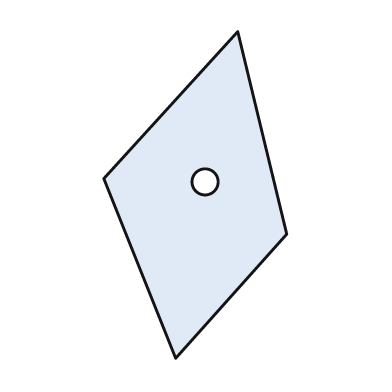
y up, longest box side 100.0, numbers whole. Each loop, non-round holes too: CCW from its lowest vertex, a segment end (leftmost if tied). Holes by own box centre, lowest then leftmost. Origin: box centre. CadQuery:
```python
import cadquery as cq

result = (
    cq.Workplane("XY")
    .moveTo(-6.0, -50.0)
    .lineTo(28.0, -12.0)
    .lineTo(13.0, 50.0)
    .lineTo(-28.0, 5.0)
    .close()
    .moveTo(3.0, 4.0)
    .circle(4.0)
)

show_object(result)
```